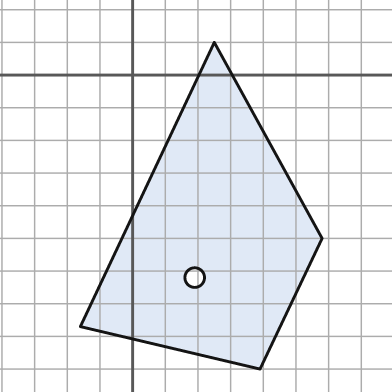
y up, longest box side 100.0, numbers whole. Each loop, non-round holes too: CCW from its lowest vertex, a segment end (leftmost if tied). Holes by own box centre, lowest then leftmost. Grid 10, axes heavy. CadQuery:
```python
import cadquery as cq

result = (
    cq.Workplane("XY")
    .moveTo(39.0, -90.0)
    .lineTo(58.0, -50.0)
    .lineTo(25.0, 10.0)
    .lineTo(-16.0, -77.0)
    .close()
    .moveTo(19.0, -62.0)
    .circle(3.0)
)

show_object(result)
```